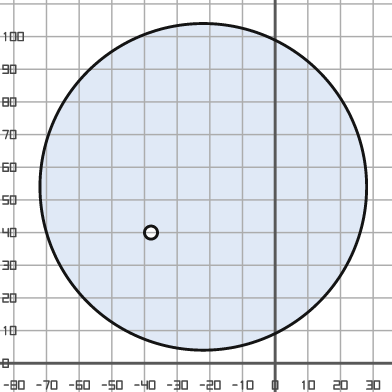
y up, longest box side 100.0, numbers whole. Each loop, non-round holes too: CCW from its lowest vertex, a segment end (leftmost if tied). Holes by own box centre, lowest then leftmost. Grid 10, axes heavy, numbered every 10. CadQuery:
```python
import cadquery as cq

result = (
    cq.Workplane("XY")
    .moveTo(-22.0, 54.0)
    .circle(50.0)
    .moveTo(-38.0, 40.0)
    .circle(2.0)
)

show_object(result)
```